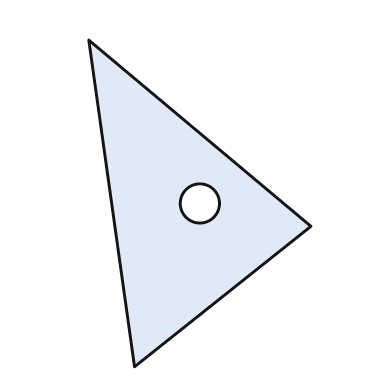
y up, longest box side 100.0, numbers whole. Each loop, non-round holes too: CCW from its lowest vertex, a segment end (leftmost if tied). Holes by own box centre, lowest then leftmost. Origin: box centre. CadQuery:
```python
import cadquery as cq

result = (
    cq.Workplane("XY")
    .moveTo(-20.0, -50.0)
    .lineTo(34.0, -7.0)
    .lineTo(-34.0, 50.0)
    .close()
    .moveTo(0.0, 0.0)
    .circle(6.0)
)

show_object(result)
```